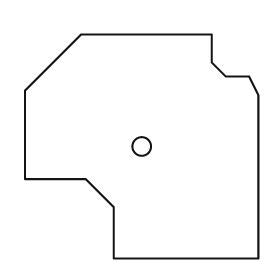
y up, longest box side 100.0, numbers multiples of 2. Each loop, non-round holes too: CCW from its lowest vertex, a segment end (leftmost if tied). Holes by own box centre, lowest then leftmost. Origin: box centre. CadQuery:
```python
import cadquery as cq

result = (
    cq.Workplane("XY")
    .moveTo(-12.0, -48.0)
    .lineTo(50.0, -48.0)
    .lineTo(50.0, 22.0)
    .lineTo(46.0, 30.0)
    .lineTo(36.0, 30.0)
    .lineTo(30.0, 36.0)
    .lineTo(30.0, 48.0)
    .lineTo(-26.0, 48.0)
    .lineTo(-50.0, 24.0)
    .lineTo(-50.0, -14.0)
    .lineTo(-24.0, -14.0)
    .lineTo(-12.0, -26.0)
    .close()
    .moveTo(0.0, 0.0)
    .circle(4.0)
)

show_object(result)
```